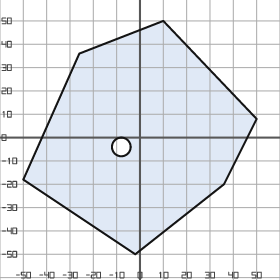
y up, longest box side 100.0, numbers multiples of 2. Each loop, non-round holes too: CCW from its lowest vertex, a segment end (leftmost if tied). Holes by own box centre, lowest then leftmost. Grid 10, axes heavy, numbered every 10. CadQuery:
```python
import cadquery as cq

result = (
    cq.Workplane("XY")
    .moveTo(-2.0, -50.0)
    .lineTo(36.0, -20.0)
    .lineTo(50.0, 8.0)
    .lineTo(10.0, 50.0)
    .lineTo(-26.0, 36.0)
    .lineTo(-50.0, -18.0)
    .close()
    .moveTo(-8.0, -4.0)
    .circle(4.0)
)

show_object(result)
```